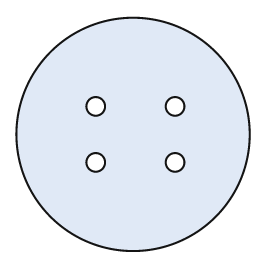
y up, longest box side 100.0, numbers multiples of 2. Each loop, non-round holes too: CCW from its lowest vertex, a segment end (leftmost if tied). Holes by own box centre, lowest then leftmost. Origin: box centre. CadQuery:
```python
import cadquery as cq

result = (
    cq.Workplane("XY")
    .moveTo(0.0, 0.0)
    .circle(50.0)
    .moveTo(-16.0, -12.0)
    .circle(4.0)
    .moveTo(18.0, -12.0)
    .circle(4.0)
    .moveTo(-16.0, 12.0)
    .circle(4.0)
    .moveTo(18.0, 12.0)
    .circle(4.0)
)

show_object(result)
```